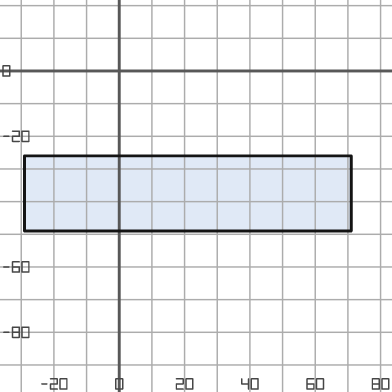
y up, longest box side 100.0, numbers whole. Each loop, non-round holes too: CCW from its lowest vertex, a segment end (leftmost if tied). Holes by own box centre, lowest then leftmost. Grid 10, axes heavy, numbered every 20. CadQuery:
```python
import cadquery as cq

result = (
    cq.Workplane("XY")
    .moveTo(-29.0, -49.0)
    .lineTo(71.0, -49.0)
    .lineTo(71.0, -26.0)
    .lineTo(-29.0, -26.0)
    .close()
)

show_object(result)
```